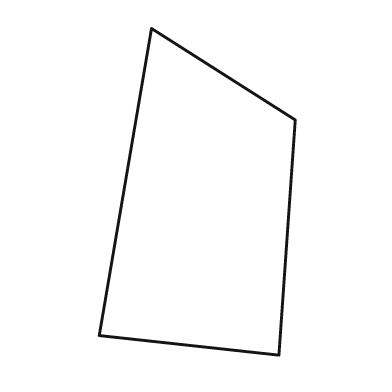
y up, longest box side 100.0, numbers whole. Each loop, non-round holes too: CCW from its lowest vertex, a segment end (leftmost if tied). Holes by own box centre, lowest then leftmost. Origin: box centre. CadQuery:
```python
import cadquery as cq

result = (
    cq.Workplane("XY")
    .moveTo(25.0, -50.0)
    .lineTo(30.0, 22.0)
    .lineTo(-14.0, 50.0)
    .lineTo(-30.0, -44.0)
    .close()
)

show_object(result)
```